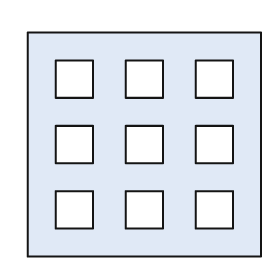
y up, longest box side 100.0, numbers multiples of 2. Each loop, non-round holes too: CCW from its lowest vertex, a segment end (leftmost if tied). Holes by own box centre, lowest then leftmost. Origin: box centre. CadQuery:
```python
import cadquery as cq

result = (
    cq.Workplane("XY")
    .moveTo(-50.0, -48.0)
    .lineTo(50.0, -48.0)
    .lineTo(50.0, 48.0)
    .lineTo(-50.0, 48.0)
    .close()
    .moveTo(-38.0, -36.0)
    .lineTo(-22.0, -36.0)
    .lineTo(-22.0, -20.0)
    .lineTo(-38.0, -20.0)
    .close()
    .moveTo(-8.0, -36.0)
    .lineTo(8.0, -36.0)
    .lineTo(8.0, -20.0)
    .lineTo(-8.0, -20.0)
    .close()
    .moveTo(22.0, -36.0)
    .lineTo(38.0, -36.0)
    .lineTo(38.0, -20.0)
    .lineTo(22.0, -20.0)
    .close()
    .moveTo(-38.0, -8.0)
    .lineTo(-22.0, -8.0)
    .lineTo(-22.0, 8.0)
    .lineTo(-38.0, 8.0)
    .close()
    .moveTo(-8.0, -8.0)
    .lineTo(8.0, -8.0)
    .lineTo(8.0, 8.0)
    .lineTo(-8.0, 8.0)
    .close()
    .moveTo(22.0, -8.0)
    .lineTo(38.0, -8.0)
    .lineTo(38.0, 8.0)
    .lineTo(22.0, 8.0)
    .close()
    .moveTo(-38.0, 20.0)
    .lineTo(-22.0, 20.0)
    .lineTo(-22.0, 36.0)
    .lineTo(-38.0, 36.0)
    .close()
    .moveTo(-8.0, 20.0)
    .lineTo(8.0, 20.0)
    .lineTo(8.0, 36.0)
    .lineTo(-8.0, 36.0)
    .close()
    .moveTo(22.0, 20.0)
    .lineTo(38.0, 20.0)
    .lineTo(38.0, 36.0)
    .lineTo(22.0, 36.0)
    .close()
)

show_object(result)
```